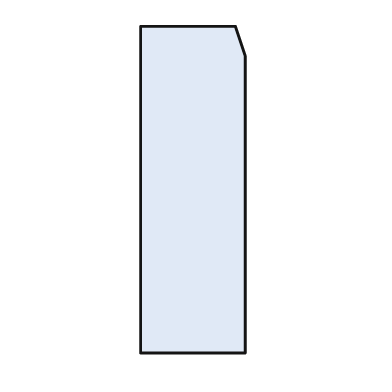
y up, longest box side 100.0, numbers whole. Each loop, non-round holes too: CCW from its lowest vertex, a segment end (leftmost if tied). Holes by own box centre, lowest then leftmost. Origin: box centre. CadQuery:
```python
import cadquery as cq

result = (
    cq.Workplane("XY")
    .moveTo(-16.0, -50.0)
    .lineTo(16.0, -50.0)
    .lineTo(16.0, 41.0)
    .lineTo(13.0, 50.0)
    .lineTo(-16.0, 50.0)
    .close()
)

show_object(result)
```